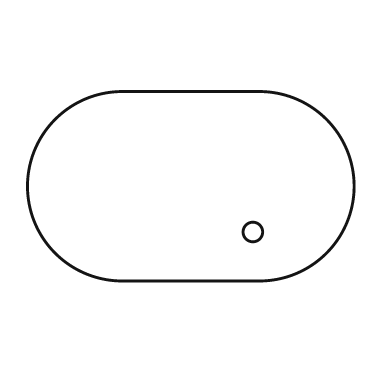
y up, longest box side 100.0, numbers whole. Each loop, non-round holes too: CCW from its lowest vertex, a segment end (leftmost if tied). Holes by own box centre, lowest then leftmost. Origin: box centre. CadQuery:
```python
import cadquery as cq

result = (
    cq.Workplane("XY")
    .moveTo(-21.0, -29.0)
    .lineTo(21.0, -29.0)
    .threePointArc((50.0, 0.0), (21.0, 29.0))
    .lineTo(-21.0, 29.0)
    .threePointArc((-50.0, 0.0), (-21.0, -29.0))
    .close()
    .moveTo(19.0, -14.0)
    .circle(3.0)
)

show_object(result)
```